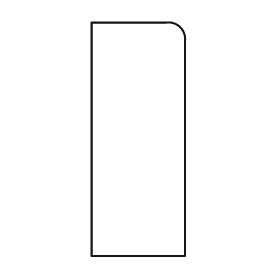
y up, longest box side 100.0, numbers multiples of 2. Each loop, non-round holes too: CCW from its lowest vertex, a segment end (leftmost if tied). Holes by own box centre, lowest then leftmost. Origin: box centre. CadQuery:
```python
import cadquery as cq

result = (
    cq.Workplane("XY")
    .moveTo(-20.0, -50.0)
    .lineTo(20.0, -50.0)
    .lineTo(20.0, 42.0)
    .threePointArc((18.0, 48.0), (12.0, 50.0))
    .lineTo(-20.0, 50.0)
    .close()
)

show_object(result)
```